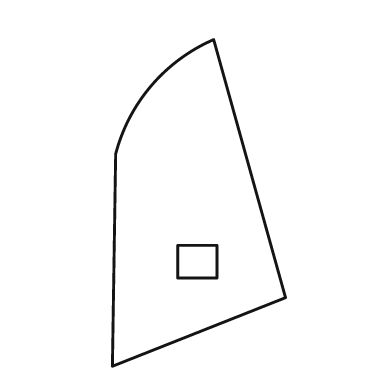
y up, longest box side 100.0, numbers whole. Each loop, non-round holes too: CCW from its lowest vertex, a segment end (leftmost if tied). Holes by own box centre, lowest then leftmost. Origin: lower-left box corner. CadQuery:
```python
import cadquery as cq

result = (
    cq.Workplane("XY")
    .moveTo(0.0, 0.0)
    .lineTo(53.0, 21.0)
    .lineTo(31.0, 100.0)
    .threePointArc((12.0, 86.0), (1.0, 65.0))
    .close()
    .moveTo(20.0, 27.0)
    .lineTo(32.0, 27.0)
    .lineTo(32.0, 37.0)
    .lineTo(20.0, 37.0)
    .close()
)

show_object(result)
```